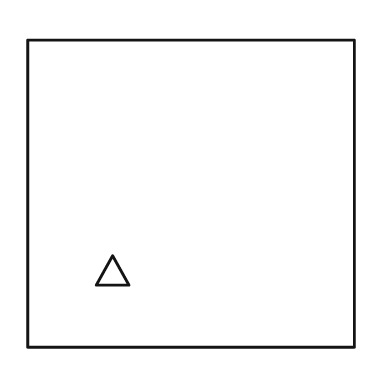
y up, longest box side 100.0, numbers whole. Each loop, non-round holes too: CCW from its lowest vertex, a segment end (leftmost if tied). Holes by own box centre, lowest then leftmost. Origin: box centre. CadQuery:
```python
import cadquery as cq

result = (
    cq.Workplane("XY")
    .moveTo(-50.0, -47.0)
    .lineTo(50.0, -47.0)
    .lineTo(50.0, 47.0)
    .lineTo(-50.0, 47.0)
    .close()
    .moveTo(-29.0, -28.0)
    .lineTo(-19.0, -28.0)
    .lineTo(-24.0, -19.0)
    .close()
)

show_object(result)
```